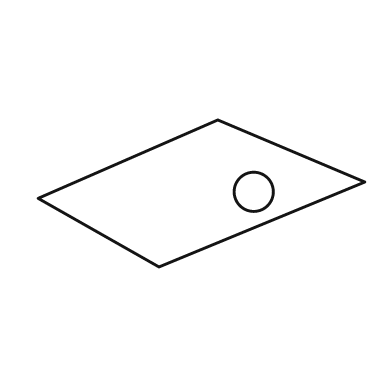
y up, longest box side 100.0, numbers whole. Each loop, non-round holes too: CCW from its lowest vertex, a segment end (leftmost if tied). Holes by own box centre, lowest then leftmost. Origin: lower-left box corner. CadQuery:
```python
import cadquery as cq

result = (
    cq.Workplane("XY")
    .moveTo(37.0, 0.0)
    .lineTo(100.0, 26.0)
    .lineTo(55.0, 45.0)
    .lineTo(0.0, 21.0)
    .close()
    .moveTo(66.0, 23.0)
    .circle(6.0)
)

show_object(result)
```